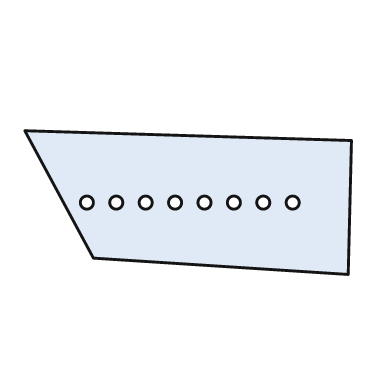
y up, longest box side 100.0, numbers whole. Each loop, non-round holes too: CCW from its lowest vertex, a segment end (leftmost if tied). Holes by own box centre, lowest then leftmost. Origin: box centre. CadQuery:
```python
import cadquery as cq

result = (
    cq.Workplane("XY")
    .moveTo(49.0, -22.0)
    .lineTo(50.0, 19.0)
    .lineTo(-50.0, 22.0)
    .lineTo(-29.0, -17.0)
    .close()
    .moveTo(-31.0, 0.0)
    .circle(2.0)
    .moveTo(-22.0, 0.0)
    .circle(2.0)
    .moveTo(-13.0, 0.0)
    .circle(2.0)
    .moveTo(-4.0, 0.0)
    .circle(2.0)
    .moveTo(5.0, 0.0)
    .circle(2.0)
    .moveTo(14.0, 0.0)
    .circle(2.0)
    .moveTo(23.0, 0.0)
    .circle(2.0)
    .moveTo(32.0, 0.0)
    .circle(2.0)
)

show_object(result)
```